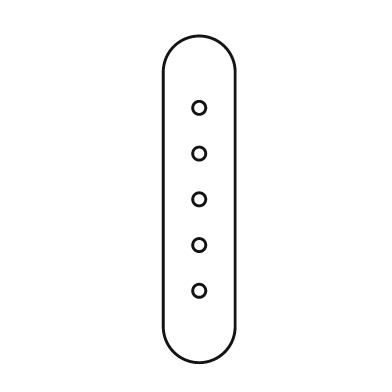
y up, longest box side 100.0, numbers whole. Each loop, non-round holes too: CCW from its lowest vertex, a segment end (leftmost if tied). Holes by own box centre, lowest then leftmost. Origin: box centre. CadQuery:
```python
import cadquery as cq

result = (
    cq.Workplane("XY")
    .moveTo(-11.0, -39.0)
    .threePointArc((0.0, -50.0), (11.0, -39.0))
    .lineTo(11.0, 39.0)
    .threePointArc((0.0, 50.0), (-11.0, 39.0))
    .close()
    .moveTo(0.0, -28.0)
    .circle(2.0)
    .moveTo(0.0, -14.0)
    .circle(2.0)
    .moveTo(0.0, 0.0)
    .circle(2.0)
    .moveTo(0.0, 14.0)
    .circle(2.0)
    .moveTo(0.0, 28.0)
    .circle(2.0)
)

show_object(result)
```